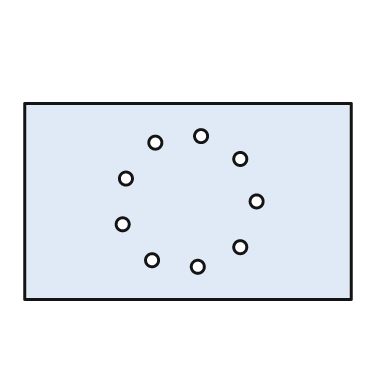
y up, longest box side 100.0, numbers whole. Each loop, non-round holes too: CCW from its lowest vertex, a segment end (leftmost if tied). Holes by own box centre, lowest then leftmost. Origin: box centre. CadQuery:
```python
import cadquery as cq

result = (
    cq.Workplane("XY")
    .moveTo(-50.0, -30.0)
    .lineTo(50.0, -30.0)
    .lineTo(50.0, 30.0)
    .lineTo(-50.0, 30.0)
    .close()
    .moveTo(3.0, -20.0)
    .circle(2.0)
    .moveTo(-11.0, -18.0)
    .circle(2.0)
    .moveTo(16.0, -14.0)
    .circle(2.0)
    .moveTo(-20.0, -7.0)
    .circle(2.0)
    .moveTo(21.0, 0.0)
    .circle(2.0)
    .moveTo(-19.0, 7.0)
    .circle(2.0)
    .moveTo(16.0, 13.0)
    .circle(2.0)
    .moveTo(-10.0, 18.0)
    .circle(2.0)
    .moveTo(4.0, 20.0)
    .circle(2.0)
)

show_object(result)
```